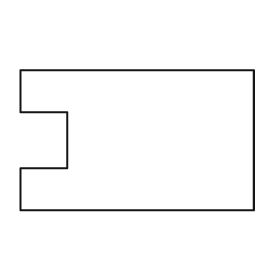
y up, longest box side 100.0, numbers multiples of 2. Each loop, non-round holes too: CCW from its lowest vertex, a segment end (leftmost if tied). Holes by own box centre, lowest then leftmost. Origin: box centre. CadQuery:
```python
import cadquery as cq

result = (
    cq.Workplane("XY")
    .moveTo(-50.0, -30.0)
    .lineTo(50.0, -30.0)
    .lineTo(50.0, 30.0)
    .lineTo(-50.0, 30.0)
    .lineTo(-50.0, 12.0)
    .lineTo(-30.0, 12.0)
    .lineTo(-30.0, -12.0)
    .lineTo(-50.0, -12.0)
    .close()
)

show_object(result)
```